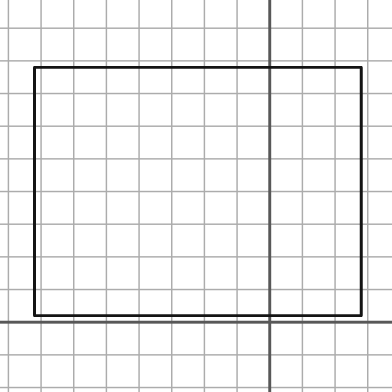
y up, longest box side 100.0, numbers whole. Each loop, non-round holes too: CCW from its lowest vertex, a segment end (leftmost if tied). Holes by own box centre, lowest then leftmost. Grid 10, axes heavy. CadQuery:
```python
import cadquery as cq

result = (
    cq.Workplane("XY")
    .moveTo(-72.0, 2.0)
    .lineTo(28.0, 2.0)
    .lineTo(28.0, 78.0)
    .lineTo(-72.0, 78.0)
    .close()
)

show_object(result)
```